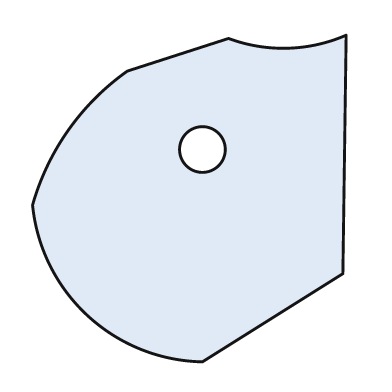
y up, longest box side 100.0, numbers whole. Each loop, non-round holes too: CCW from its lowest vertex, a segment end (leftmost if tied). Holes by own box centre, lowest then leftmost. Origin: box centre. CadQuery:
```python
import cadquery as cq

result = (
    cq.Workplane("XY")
    .moveTo(4.0, -50.0)
    .lineTo(47.0, -23.0)
    .lineTo(48.0, 50.0)
    .threePointArc((30.0, 46.0), (12.0, 49.0))
    .lineTo(-19.0, 39.0)
    .threePointArc((-37.0, 21.0), (-48.0, -2.0))
    .threePointArc((-31.0, -36.0), (4.0, -50.0))
    .close()
    .moveTo(4.0, 15.0)
    .circle(7.0)
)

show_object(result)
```